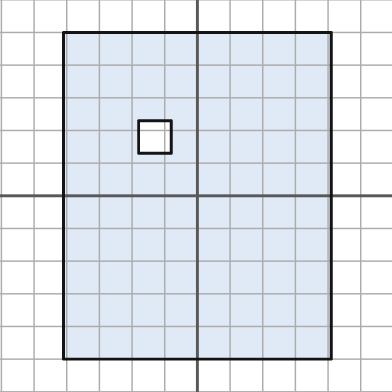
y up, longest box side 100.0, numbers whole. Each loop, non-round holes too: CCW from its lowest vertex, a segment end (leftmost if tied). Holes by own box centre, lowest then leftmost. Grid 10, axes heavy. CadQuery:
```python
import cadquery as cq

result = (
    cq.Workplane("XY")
    .moveTo(-41.0, -50.0)
    .lineTo(41.0, -50.0)
    .lineTo(41.0, 50.0)
    .lineTo(-41.0, 50.0)
    .close()
    .moveTo(-18.0, 13.0)
    .lineTo(-8.0, 13.0)
    .lineTo(-8.0, 23.0)
    .lineTo(-18.0, 23.0)
    .close()
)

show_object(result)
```